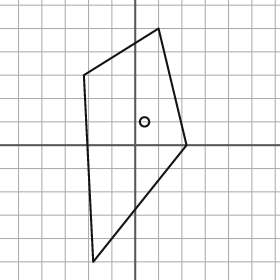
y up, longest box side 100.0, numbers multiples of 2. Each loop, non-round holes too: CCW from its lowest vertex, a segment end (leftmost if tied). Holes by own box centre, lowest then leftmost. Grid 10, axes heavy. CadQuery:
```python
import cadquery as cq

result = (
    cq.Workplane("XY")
    .moveTo(-18.0, -50.0)
    .lineTo(22.0, 0.0)
    .lineTo(10.0, 50.0)
    .lineTo(-22.0, 30.0)
    .close()
    .moveTo(4.0, 10.0)
    .circle(2.0)
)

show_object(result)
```